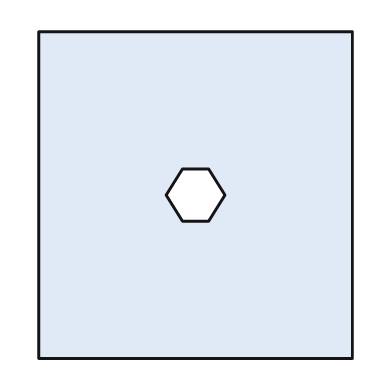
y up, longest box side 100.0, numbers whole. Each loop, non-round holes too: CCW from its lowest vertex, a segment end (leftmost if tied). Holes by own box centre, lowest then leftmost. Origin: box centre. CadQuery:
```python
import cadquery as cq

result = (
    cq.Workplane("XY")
    .moveTo(-48.0, -50.0)
    .lineTo(48.0, -50.0)
    .lineTo(48.0, 50.0)
    .lineTo(-48.0, 50.0)
    .close()
    .moveTo(-4.0, -8.0)
    .lineTo(4.0, -8.0)
    .lineTo(9.0, 0.0)
    .lineTo(4.0, 8.0)
    .lineTo(-4.0, 8.0)
    .lineTo(-9.0, 0.0)
    .close()
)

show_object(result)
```